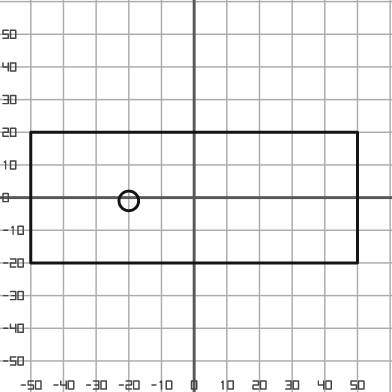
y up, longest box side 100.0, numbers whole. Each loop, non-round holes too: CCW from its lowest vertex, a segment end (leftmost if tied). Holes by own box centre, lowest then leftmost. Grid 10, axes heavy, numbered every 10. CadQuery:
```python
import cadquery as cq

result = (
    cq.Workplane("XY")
    .moveTo(-50.0, -20.0)
    .lineTo(50.0, -20.0)
    .lineTo(50.0, 20.0)
    .lineTo(-50.0, 20.0)
    .close()
    .moveTo(-20.0, -1.0)
    .circle(3.0)
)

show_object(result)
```